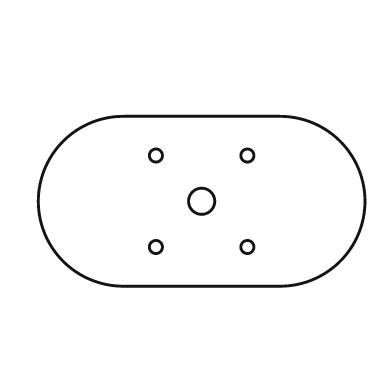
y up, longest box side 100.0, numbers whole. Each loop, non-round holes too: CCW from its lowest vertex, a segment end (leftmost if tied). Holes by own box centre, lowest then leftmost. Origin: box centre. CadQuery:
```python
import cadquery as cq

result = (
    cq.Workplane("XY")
    .moveTo(-24.0, -26.0)
    .lineTo(24.0, -26.0)
    .threePointArc((50.0, 0.0), (24.0, 26.0))
    .lineTo(-24.0, 26.0)
    .threePointArc((-50.0, 0.0), (-24.0, -26.0))
    .close()
    .moveTo(-14.0, -14.0)
    .circle(2.0)
    .moveTo(14.0, -14.0)
    .circle(2.0)
    .moveTo(0.0, 0.0)
    .circle(4.0)
    .moveTo(-14.0, 14.0)
    .circle(2.0)
    .moveTo(14.0, 14.0)
    .circle(2.0)
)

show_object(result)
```